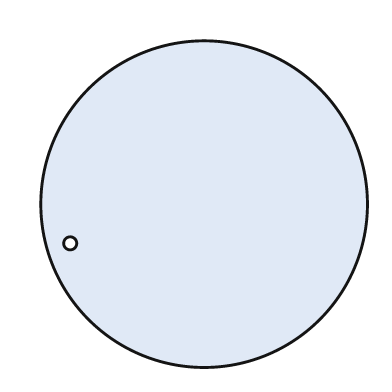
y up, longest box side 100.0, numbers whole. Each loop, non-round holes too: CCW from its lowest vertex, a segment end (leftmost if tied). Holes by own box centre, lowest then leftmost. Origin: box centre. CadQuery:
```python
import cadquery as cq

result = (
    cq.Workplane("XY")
    .moveTo(0.0, 0.0)
    .circle(50.0)
    .moveTo(-41.0, -12.0)
    .circle(2.0)
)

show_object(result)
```